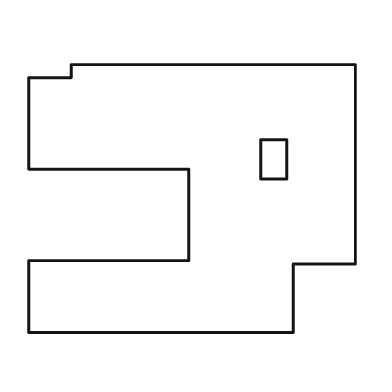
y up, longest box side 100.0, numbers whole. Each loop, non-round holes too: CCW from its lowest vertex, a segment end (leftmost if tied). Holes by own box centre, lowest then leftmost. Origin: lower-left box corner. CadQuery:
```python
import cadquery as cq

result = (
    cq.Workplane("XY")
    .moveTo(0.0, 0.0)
    .lineTo(81.0, 0.0)
    .lineTo(81.0, 21.0)
    .lineTo(100.0, 21.0)
    .lineTo(100.0, 82.0)
    .lineTo(13.0, 82.0)
    .lineTo(13.0, 78.0)
    .lineTo(0.0, 78.0)
    .lineTo(0.0, 50.0)
    .lineTo(49.0, 50.0)
    .lineTo(49.0, 22.0)
    .lineTo(0.0, 22.0)
    .close()
    .moveTo(71.0, 47.0)
    .lineTo(79.0, 47.0)
    .lineTo(79.0, 59.0)
    .lineTo(71.0, 59.0)
    .close()
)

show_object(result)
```